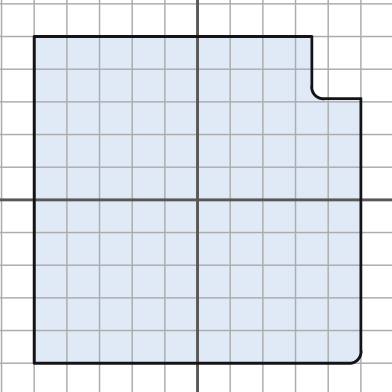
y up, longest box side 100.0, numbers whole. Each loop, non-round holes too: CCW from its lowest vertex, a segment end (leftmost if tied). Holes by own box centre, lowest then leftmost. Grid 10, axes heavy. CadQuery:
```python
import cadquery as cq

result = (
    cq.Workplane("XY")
    .moveTo(-50.0, -50.0)
    .lineTo(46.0, -50.0)
    .threePointArc((49.0, -49.0), (50.0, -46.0))
    .lineTo(50.0, 31.0)
    .lineTo(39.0, 31.0)
    .threePointArc((36.0, 32.0), (35.0, 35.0))
    .lineTo(35.0, 50.0)
    .lineTo(-50.0, 50.0)
    .close()
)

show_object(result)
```